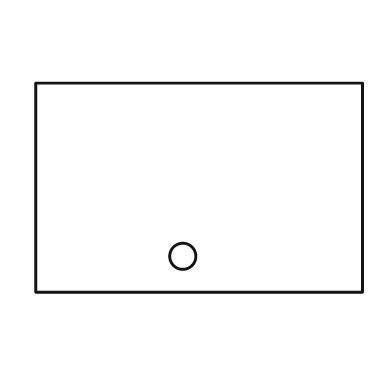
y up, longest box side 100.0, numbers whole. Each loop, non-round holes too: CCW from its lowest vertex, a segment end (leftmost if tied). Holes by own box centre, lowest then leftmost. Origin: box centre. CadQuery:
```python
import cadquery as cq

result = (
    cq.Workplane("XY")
    .moveTo(-50.0, -32.0)
    .lineTo(50.0, -32.0)
    .lineTo(50.0, 32.0)
    .lineTo(-50.0, 32.0)
    .close()
    .moveTo(-5.0, -21.0)
    .circle(4.0)
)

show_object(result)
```